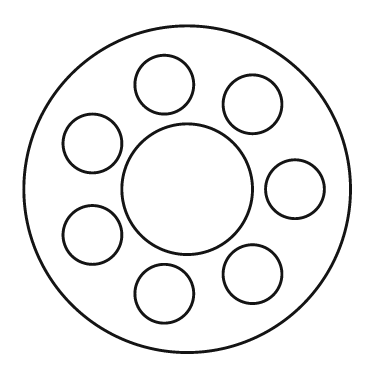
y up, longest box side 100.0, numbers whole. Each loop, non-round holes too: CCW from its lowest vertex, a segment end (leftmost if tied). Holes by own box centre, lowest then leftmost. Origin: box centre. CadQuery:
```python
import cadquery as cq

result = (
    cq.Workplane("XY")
    .moveTo(0.0, 0.0)
    .circle(50.0)
    .moveTo(-7.0, -32.0)
    .circle(9.0)
    .moveTo(20.0, -26.0)
    .circle(9.0)
    .moveTo(-29.0, -14.0)
    .circle(9.0)
    .moveTo(0.0, 0.0)
    .circle(20.0)
    .moveTo(33.0, 0.0)
    .circle(9.0)
    .moveTo(-29.0, 14.0)
    .circle(9.0)
    .moveTo(20.0, 26.0)
    .circle(9.0)
    .moveTo(-7.0, 32.0)
    .circle(9.0)
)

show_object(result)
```